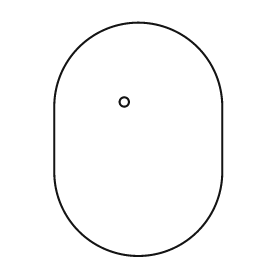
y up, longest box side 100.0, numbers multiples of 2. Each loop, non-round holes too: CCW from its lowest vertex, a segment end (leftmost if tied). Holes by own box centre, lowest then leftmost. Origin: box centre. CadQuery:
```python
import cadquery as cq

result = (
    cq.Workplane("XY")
    .moveTo(-36.0, -14.0)
    .threePointArc((0.0, -50.0), (36.0, -14.0))
    .lineTo(36.0, 14.0)
    .threePointArc((0.0, 50.0), (-36.0, 14.0))
    .close()
    .moveTo(-6.0, 16.0)
    .circle(2.0)
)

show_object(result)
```